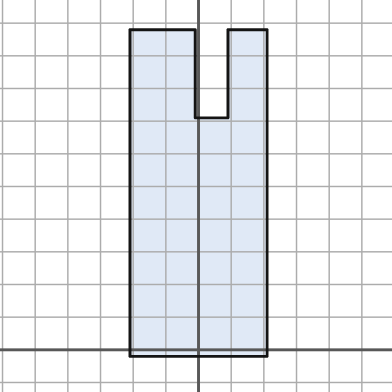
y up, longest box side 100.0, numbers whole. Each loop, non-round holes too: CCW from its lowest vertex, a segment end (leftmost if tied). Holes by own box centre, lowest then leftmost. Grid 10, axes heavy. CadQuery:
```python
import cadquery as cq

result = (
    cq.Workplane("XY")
    .moveTo(-21.0, -2.0)
    .lineTo(21.0, -2.0)
    .lineTo(21.0, 98.0)
    .lineTo(9.0, 98.0)
    .lineTo(9.0, 71.0)
    .lineTo(-1.0, 71.0)
    .lineTo(-1.0, 98.0)
    .lineTo(-21.0, 98.0)
    .close()
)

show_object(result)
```